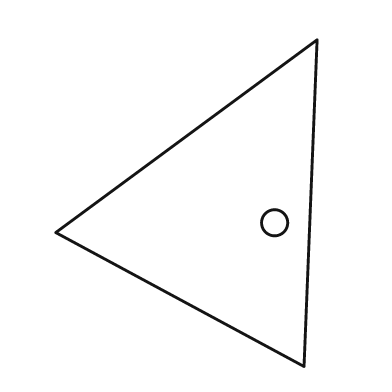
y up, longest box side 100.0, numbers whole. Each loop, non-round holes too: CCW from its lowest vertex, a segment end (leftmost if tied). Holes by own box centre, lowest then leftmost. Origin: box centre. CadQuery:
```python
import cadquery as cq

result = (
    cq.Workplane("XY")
    .moveTo(36.0, -50.0)
    .lineTo(40.0, 50.0)
    .lineTo(-40.0, -9.0)
    .close()
    .moveTo(27.0, -6.0)
    .circle(4.0)
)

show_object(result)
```